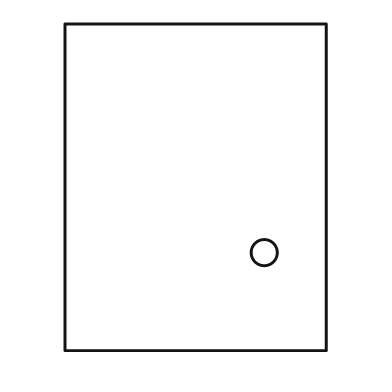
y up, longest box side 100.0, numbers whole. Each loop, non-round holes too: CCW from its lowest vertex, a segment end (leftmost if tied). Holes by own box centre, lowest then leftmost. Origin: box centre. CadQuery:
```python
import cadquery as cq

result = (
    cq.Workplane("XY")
    .moveTo(-40.0, -50.0)
    .lineTo(40.0, -50.0)
    .lineTo(40.0, 50.0)
    .lineTo(-40.0, 50.0)
    .close()
    .moveTo(21.0, -20.0)
    .circle(4.0)
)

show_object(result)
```